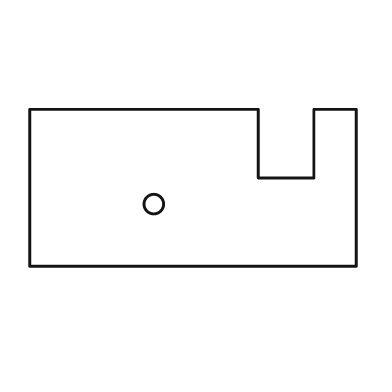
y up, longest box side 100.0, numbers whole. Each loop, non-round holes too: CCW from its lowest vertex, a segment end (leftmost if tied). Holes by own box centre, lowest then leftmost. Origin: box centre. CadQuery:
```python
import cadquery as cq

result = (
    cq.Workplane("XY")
    .moveTo(-50.0, -24.0)
    .lineTo(50.0, -24.0)
    .lineTo(50.0, 24.0)
    .lineTo(37.0, 24.0)
    .lineTo(37.0, 3.0)
    .lineTo(20.0, 3.0)
    .lineTo(20.0, 24.0)
    .lineTo(-50.0, 24.0)
    .close()
    .moveTo(-12.0, -5.0)
    .circle(3.0)
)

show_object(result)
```